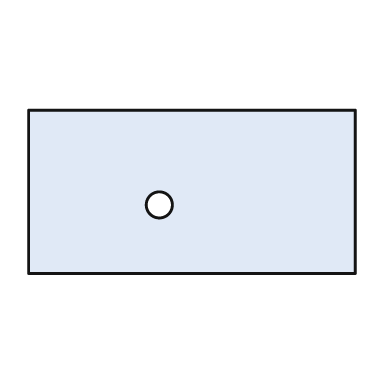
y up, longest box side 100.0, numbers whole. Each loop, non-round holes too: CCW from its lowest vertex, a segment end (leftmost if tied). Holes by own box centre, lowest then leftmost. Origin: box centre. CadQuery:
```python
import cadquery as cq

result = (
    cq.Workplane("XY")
    .moveTo(-50.0, -25.0)
    .lineTo(50.0, -25.0)
    .lineTo(50.0, 25.0)
    .lineTo(-50.0, 25.0)
    .close()
    .moveTo(-10.0, -4.0)
    .circle(4.0)
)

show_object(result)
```